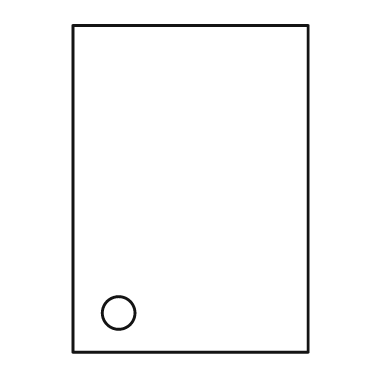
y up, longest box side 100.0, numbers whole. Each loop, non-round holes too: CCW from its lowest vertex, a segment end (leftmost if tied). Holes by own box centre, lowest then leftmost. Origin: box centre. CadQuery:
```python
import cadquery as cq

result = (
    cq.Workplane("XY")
    .moveTo(-36.0, -50.0)
    .lineTo(36.0, -50.0)
    .lineTo(36.0, 50.0)
    .lineTo(-36.0, 50.0)
    .close()
    .moveTo(-22.0, -38.0)
    .circle(5.0)
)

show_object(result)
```